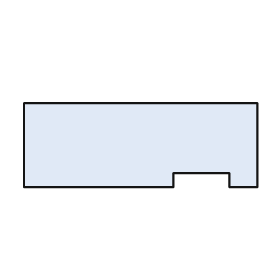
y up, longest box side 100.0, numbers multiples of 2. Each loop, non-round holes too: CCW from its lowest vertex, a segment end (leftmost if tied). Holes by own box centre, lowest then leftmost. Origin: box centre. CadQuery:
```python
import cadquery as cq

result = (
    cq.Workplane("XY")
    .moveTo(-50.0, -18.0)
    .lineTo(14.0, -18.0)
    .lineTo(14.0, -12.0)
    .lineTo(38.0, -12.0)
    .lineTo(38.0, -18.0)
    .lineTo(50.0, -18.0)
    .lineTo(50.0, 18.0)
    .lineTo(-50.0, 18.0)
    .close()
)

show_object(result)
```